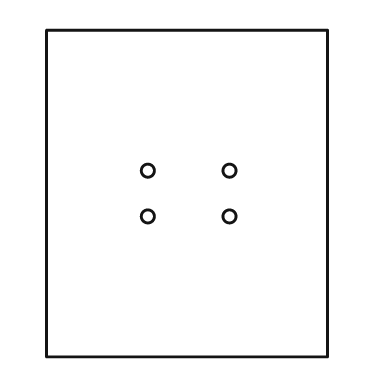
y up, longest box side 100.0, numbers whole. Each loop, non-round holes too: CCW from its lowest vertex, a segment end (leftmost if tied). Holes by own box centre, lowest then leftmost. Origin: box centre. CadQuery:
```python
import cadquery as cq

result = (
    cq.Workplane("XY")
    .moveTo(-43.0, -50.0)
    .lineTo(43.0, -50.0)
    .lineTo(43.0, 50.0)
    .lineTo(-43.0, 50.0)
    .close()
    .moveTo(-12.0, -7.0)
    .circle(2.0)
    .moveTo(13.0, -7.0)
    .circle(2.0)
    .moveTo(-12.0, 7.0)
    .circle(2.0)
    .moveTo(13.0, 7.0)
    .circle(2.0)
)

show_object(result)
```